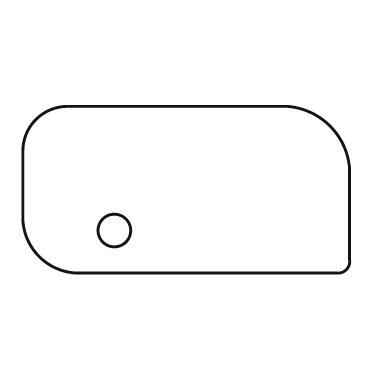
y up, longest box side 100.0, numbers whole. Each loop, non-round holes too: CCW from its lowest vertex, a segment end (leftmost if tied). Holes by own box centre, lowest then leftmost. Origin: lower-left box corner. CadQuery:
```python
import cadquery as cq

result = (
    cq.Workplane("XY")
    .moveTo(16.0, 0.0)
    .lineTo(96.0, 0.0)
    .threePointArc((99.0, 1.0), (100.0, 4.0))
    .lineTo(100.0, 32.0)
    .threePointArc((94.0, 45.0), (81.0, 51.0))
    .lineTo(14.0, 51.0)
    .threePointArc((4.0, 47.0), (0.0, 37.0))
    .lineTo(0.0, 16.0)
    .threePointArc((5.0, 5.0), (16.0, 0.0))
    .close()
    .moveTo(28.0, 13.0)
    .circle(5.0)
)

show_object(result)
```